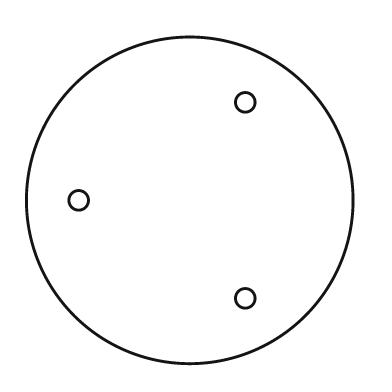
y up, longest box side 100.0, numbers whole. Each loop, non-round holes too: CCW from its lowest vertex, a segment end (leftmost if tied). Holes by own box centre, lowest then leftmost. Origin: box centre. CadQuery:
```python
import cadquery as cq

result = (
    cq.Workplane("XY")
    .moveTo(0.0, 0.0)
    .circle(50.0)
    .moveTo(17.0, -30.0)
    .circle(3.0)
    .moveTo(-34.0, 0.0)
    .circle(3.0)
    .moveTo(17.0, 30.0)
    .circle(3.0)
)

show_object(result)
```